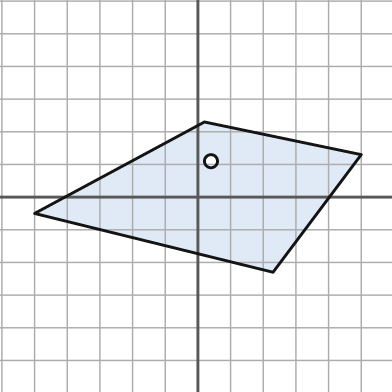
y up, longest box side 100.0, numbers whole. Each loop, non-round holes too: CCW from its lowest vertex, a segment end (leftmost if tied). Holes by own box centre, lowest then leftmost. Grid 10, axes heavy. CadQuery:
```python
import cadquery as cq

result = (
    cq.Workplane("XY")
    .moveTo(23.0, -23.0)
    .lineTo(50.0, 13.0)
    .lineTo(2.0, 23.0)
    .lineTo(-50.0, -5.0)
    .close()
    .moveTo(4.0, 11.0)
    .circle(2.0)
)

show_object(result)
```